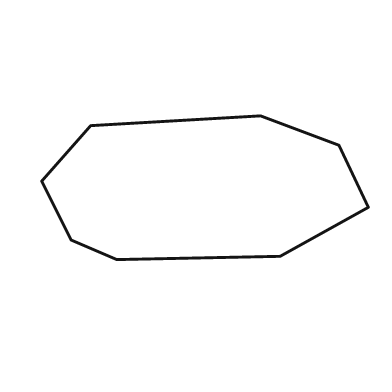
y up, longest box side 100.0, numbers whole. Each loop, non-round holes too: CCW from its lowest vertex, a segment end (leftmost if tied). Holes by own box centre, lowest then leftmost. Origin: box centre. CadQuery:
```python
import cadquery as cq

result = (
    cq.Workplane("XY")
    .moveTo(-27.0, -22.0)
    .lineTo(23.0, -21.0)
    .lineTo(50.0, -6.0)
    .lineTo(41.0, 13.0)
    .lineTo(17.0, 22.0)
    .lineTo(-35.0, 19.0)
    .lineTo(-50.0, 2.0)
    .lineTo(-41.0, -16.0)
    .close()
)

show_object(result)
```